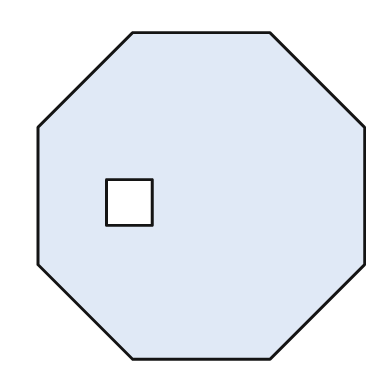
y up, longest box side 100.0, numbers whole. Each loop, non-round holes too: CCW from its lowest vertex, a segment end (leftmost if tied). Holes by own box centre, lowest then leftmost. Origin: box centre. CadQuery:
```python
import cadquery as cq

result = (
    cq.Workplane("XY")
    .moveTo(-21.0, -50.0)
    .lineTo(21.0, -50.0)
    .lineTo(50.0, -21.0)
    .lineTo(50.0, 21.0)
    .lineTo(21.0, 50.0)
    .lineTo(-21.0, 50.0)
    .lineTo(-50.0, 21.0)
    .lineTo(-50.0, -21.0)
    .close()
    .moveTo(-29.0, -9.0)
    .lineTo(-15.0, -9.0)
    .lineTo(-15.0, 5.0)
    .lineTo(-29.0, 5.0)
    .close()
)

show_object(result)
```